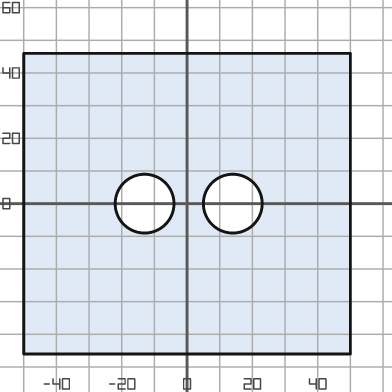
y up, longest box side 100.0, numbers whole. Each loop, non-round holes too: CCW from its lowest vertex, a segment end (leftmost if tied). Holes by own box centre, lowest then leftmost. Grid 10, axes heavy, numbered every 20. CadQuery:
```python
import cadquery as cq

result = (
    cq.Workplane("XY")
    .moveTo(-50.0, -46.0)
    .lineTo(50.0, -46.0)
    .lineTo(50.0, 46.0)
    .lineTo(-50.0, 46.0)
    .close()
    .moveTo(-13.0, 0.0)
    .circle(9.0)
    .moveTo(14.0, 0.0)
    .circle(9.0)
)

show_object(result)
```